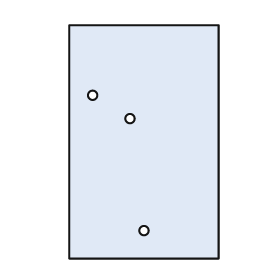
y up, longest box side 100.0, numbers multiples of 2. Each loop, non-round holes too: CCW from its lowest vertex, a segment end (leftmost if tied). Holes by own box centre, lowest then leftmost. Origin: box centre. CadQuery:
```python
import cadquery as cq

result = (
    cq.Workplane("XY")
    .moveTo(-32.0, -50.0)
    .lineTo(32.0, -50.0)
    .lineTo(32.0, 50.0)
    .lineTo(-32.0, 50.0)
    .close()
    .moveTo(0.0, -38.0)
    .circle(2.0)
    .moveTo(-6.0, 10.0)
    .circle(2.0)
    .moveTo(-22.0, 20.0)
    .circle(2.0)
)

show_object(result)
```